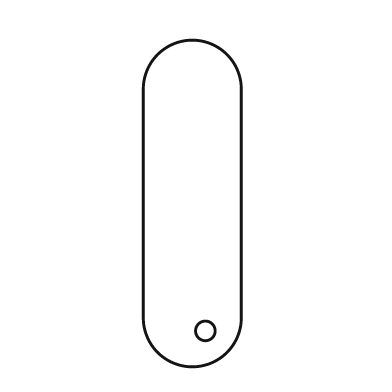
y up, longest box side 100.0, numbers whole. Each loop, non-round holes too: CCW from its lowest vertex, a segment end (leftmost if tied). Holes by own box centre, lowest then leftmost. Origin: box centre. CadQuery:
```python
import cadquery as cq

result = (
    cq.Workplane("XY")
    .moveTo(-15.0, -35.0)
    .threePointArc((0.0, -50.0), (15.0, -35.0))
    .lineTo(15.0, 35.0)
    .threePointArc((0.0, 50.0), (-15.0, 35.0))
    .close()
    .moveTo(4.0, -39.0)
    .circle(3.0)
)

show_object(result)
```